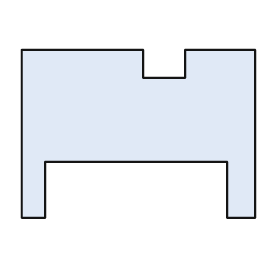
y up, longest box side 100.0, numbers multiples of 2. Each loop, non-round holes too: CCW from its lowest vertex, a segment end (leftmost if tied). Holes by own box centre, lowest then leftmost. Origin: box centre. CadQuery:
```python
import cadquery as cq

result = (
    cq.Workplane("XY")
    .moveTo(-50.0, -36.0)
    .lineTo(-40.0, -36.0)
    .lineTo(-40.0, -12.0)
    .lineTo(38.0, -12.0)
    .lineTo(38.0, -36.0)
    .lineTo(50.0, -36.0)
    .lineTo(50.0, 36.0)
    .lineTo(20.0, 36.0)
    .lineTo(20.0, 24.0)
    .lineTo(2.0, 24.0)
    .lineTo(2.0, 36.0)
    .lineTo(-50.0, 36.0)
    .close()
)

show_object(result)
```